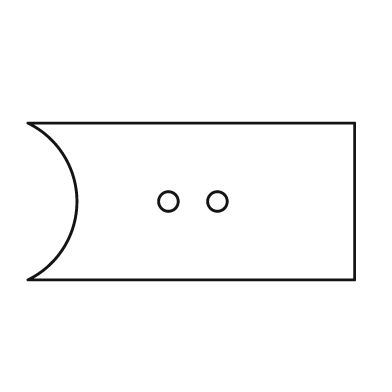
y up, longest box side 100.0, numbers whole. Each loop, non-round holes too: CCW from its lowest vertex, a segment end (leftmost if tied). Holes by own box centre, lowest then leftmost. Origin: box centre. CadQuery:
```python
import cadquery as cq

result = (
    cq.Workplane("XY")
    .moveTo(-50.0, -24.0)
    .lineTo(50.0, -24.0)
    .lineTo(50.0, 24.0)
    .lineTo(-50.0, 24.0)
    .threePointArc((-35.0, 0.0), (-50.0, -24.0))
    .close()
    .moveTo(-7.0, 0.0)
    .circle(3.0)
    .moveTo(8.0, 0.0)
    .circle(3.0)
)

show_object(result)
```